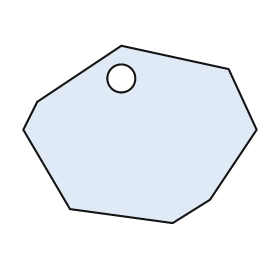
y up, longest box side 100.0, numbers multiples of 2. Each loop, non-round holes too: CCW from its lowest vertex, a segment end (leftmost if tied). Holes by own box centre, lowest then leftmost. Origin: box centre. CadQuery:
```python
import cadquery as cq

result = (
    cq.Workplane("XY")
    .moveTo(14.0, -38.0)
    .lineTo(30.0, -28.0)
    .lineTo(50.0, 2.0)
    .lineTo(38.0, 28.0)
    .lineTo(-8.0, 38.0)
    .lineTo(-44.0, 14.0)
    .lineTo(-50.0, 2.0)
    .lineTo(-30.0, -32.0)
    .close()
    .moveTo(-8.0, 24.0)
    .circle(6.0)
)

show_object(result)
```